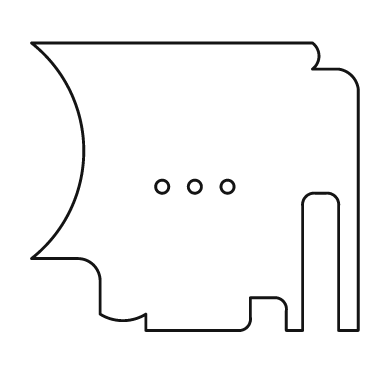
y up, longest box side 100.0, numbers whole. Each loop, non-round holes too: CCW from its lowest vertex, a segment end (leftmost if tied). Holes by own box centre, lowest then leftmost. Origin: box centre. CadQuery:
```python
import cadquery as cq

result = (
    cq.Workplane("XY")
    .moveTo(-15.0, -44.0)
    .lineTo(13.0, -44.0)
    .threePointArc((16.0, -43.0), (17.0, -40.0))
    .lineTo(17.0, -34.0)
    .lineTo(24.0, -34.0)
    .threePointArc((27.0, -35.0), (28.0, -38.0))
    .lineTo(28.0, -44.0)
    .lineTo(33.0, -44.0)
    .lineTo(33.0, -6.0)
    .threePointArc((34.0, -3.0), (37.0, -2.0))
    .lineTo(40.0, -2.0)
    .threePointArc((43.0, -3.0), (44.0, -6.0))
    .lineTo(44.0, -44.0)
    .lineTo(50.0, -44.0)
    .lineTo(50.0, 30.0)
    .threePointArc((48.0, 34.0), (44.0, 36.0))
    .lineTo(36.0, 36.0)
    .threePointArc((38.0, 40.0), (36.0, 44.0))
    .lineTo(-50.0, 44.0)
    .threePointArc((-34.0, 11.0), (-50.0, -22.0))
    .lineTo(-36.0, -22.0)
    .threePointArc((-31.0, -24.0), (-29.0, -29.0))
    .lineTo(-29.0, -39.0)
    .threePointArc((-22.0, -41.0), (-15.0, -39.0))
    .close()
    .moveTo(-10.0, 0.0)
    .circle(2.0)
    .moveTo(0.0, 0.0)
    .circle(2.0)
    .moveTo(10.0, 0.0)
    .circle(2.0)
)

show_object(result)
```